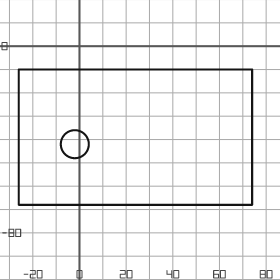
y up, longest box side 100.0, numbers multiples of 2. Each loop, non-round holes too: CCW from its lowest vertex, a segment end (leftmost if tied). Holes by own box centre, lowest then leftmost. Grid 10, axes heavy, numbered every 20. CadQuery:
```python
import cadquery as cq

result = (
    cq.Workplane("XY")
    .moveTo(-26.0, -68.0)
    .lineTo(74.0, -68.0)
    .lineTo(74.0, -10.0)
    .lineTo(-26.0, -10.0)
    .close()
    .moveTo(-2.0, -42.0)
    .circle(6.0)
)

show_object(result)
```